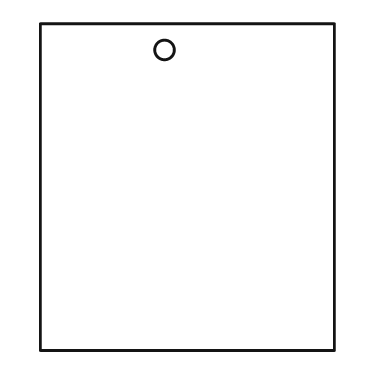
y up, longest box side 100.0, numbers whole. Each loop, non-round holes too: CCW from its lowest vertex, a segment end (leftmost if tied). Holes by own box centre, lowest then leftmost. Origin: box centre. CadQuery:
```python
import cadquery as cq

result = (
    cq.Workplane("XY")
    .moveTo(-45.0, -50.0)
    .lineTo(45.0, -50.0)
    .lineTo(45.0, 50.0)
    .lineTo(-45.0, 50.0)
    .close()
    .moveTo(-7.0, 42.0)
    .circle(3.0)
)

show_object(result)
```